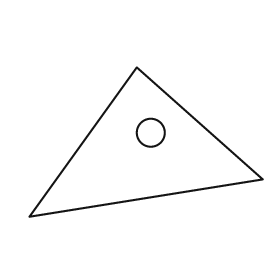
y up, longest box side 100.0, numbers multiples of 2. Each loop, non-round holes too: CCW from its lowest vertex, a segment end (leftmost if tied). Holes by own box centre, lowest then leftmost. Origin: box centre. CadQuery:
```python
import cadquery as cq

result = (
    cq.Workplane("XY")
    .moveTo(-50.0, -32.0)
    .lineTo(50.0, -16.0)
    .lineTo(-4.0, 32.0)
    .close()
    .moveTo(2.0, 4.0)
    .circle(6.0)
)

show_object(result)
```